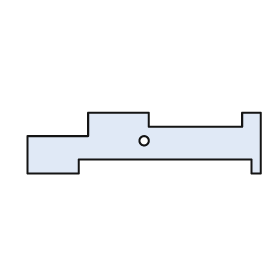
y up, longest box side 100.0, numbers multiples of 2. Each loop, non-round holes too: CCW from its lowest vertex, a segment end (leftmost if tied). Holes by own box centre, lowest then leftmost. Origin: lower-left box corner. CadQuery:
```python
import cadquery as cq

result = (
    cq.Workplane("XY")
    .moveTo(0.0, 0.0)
    .lineTo(22.0, 0.0)
    .lineTo(22.0, 6.0)
    .lineTo(96.0, 6.0)
    .lineTo(96.0, 0.0)
    .lineTo(100.0, 0.0)
    .lineTo(100.0, 26.0)
    .lineTo(92.0, 26.0)
    .lineTo(92.0, 20.0)
    .lineTo(52.0, 20.0)
    .lineTo(52.0, 26.0)
    .lineTo(26.0, 26.0)
    .lineTo(26.0, 16.0)
    .lineTo(0.0, 16.0)
    .close()
    .moveTo(50.0, 14.0)
    .circle(2.0)
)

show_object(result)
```